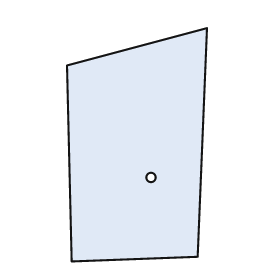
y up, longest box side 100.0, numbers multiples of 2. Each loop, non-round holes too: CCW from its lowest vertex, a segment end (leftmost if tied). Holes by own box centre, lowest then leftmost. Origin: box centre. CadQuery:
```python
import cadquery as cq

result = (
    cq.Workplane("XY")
    .moveTo(-28.0, -50.0)
    .lineTo(26.0, -48.0)
    .lineTo(30.0, 50.0)
    .lineTo(-30.0, 34.0)
    .close()
    .moveTo(6.0, -14.0)
    .circle(2.0)
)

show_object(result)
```